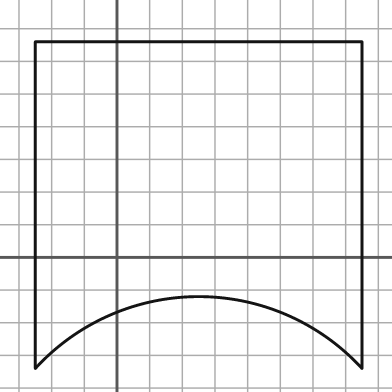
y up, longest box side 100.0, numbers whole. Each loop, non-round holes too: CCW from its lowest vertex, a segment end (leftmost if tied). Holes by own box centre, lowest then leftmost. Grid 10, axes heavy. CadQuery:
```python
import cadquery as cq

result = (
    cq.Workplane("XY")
    .moveTo(-25.0, -34.0)
    .threePointArc((25.0, -12.0), (75.0, -34.0))
    .lineTo(75.0, 66.0)
    .lineTo(-25.0, 66.0)
    .close()
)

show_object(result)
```